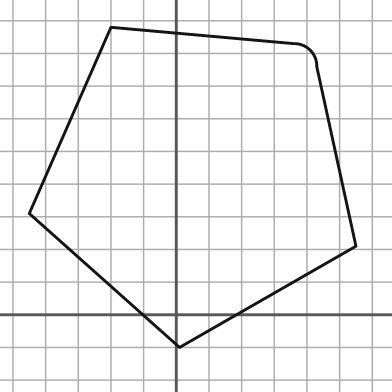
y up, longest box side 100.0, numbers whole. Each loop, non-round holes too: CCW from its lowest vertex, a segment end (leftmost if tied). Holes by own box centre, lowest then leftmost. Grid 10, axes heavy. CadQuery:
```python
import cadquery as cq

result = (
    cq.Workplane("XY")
    .moveTo(1.0, -10.0)
    .lineTo(55.0, 21.0)
    .lineTo(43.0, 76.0)
    .threePointArc((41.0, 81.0), (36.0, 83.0))
    .lineTo(-20.0, 88.0)
    .lineTo(-45.0, 31.0)
    .close()
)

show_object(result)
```